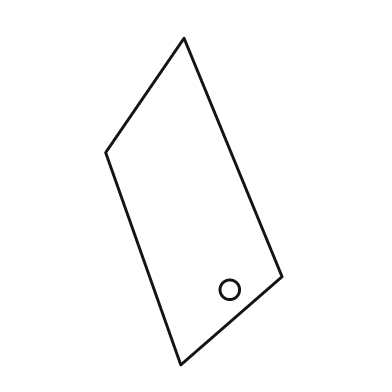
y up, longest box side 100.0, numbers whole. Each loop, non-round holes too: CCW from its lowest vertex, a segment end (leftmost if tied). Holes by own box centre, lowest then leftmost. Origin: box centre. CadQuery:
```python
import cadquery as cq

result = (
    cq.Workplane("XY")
    .moveTo(-4.0, -50.0)
    .lineTo(27.0, -23.0)
    .lineTo(-3.0, 50.0)
    .lineTo(-27.0, 15.0)
    .close()
    .moveTo(11.0, -27.0)
    .circle(3.0)
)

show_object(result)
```